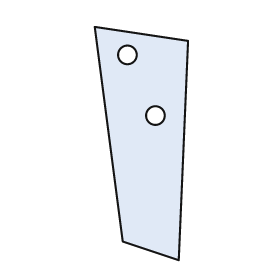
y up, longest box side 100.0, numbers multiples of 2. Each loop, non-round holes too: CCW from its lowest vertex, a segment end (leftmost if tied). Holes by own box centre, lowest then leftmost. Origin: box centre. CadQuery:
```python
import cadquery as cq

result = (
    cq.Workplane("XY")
    .moveTo(16.0, -50.0)
    .lineTo(20.0, 44.0)
    .lineTo(-20.0, 50.0)
    .lineTo(-8.0, -42.0)
    .close()
    .moveTo(6.0, 12.0)
    .circle(4.0)
    .moveTo(-6.0, 38.0)
    .circle(4.0)
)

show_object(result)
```